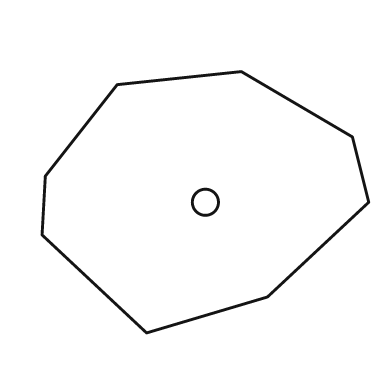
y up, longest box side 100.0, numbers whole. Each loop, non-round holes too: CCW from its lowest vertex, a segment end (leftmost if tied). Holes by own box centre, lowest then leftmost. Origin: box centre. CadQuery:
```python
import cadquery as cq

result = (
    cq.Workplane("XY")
    .moveTo(-18.0, -40.0)
    .lineTo(19.0, -29.0)
    .lineTo(50.0, 0.0)
    .lineTo(45.0, 20.0)
    .lineTo(11.0, 40.0)
    .lineTo(-27.0, 36.0)
    .lineTo(-49.0, 8.0)
    .lineTo(-50.0, -10.0)
    .close()
    .moveTo(0.0, 0.0)
    .circle(4.0)
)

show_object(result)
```